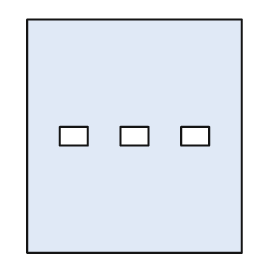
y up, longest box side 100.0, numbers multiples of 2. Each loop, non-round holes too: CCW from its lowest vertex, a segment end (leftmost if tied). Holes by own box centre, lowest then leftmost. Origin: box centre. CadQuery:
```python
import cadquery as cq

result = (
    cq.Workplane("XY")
    .moveTo(-46.0, -50.0)
    .lineTo(46.0, -50.0)
    .lineTo(46.0, 50.0)
    .lineTo(-46.0, 50.0)
    .close()
    .moveTo(-32.0, -4.0)
    .lineTo(-20.0, -4.0)
    .lineTo(-20.0, 4.0)
    .lineTo(-32.0, 4.0)
    .close()
    .moveTo(-6.0, -4.0)
    .lineTo(6.0, -4.0)
    .lineTo(6.0, 4.0)
    .lineTo(-6.0, 4.0)
    .close()
    .moveTo(20.0, -4.0)
    .lineTo(32.0, -4.0)
    .lineTo(32.0, 4.0)
    .lineTo(20.0, 4.0)
    .close()
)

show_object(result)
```